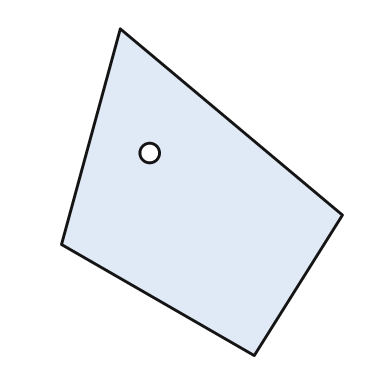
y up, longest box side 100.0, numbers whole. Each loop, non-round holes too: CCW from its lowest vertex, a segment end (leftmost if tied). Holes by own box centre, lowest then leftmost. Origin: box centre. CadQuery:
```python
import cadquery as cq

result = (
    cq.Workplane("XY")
    .moveTo(16.0, -50.0)
    .lineTo(43.0, -7.0)
    .lineTo(-25.0, 50.0)
    .lineTo(-43.0, -16.0)
    .close()
    .moveTo(-16.0, 12.0)
    .circle(3.0)
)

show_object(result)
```